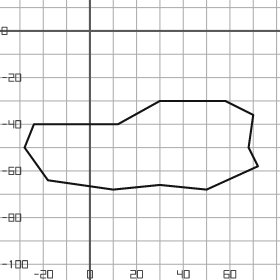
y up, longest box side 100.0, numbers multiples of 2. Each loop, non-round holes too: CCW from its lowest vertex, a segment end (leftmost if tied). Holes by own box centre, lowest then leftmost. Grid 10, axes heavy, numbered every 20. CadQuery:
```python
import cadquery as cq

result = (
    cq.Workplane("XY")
    .moveTo(10.0, -68.0)
    .lineTo(30.0, -66.0)
    .lineTo(50.0, -68.0)
    .lineTo(72.0, -58.0)
    .lineTo(68.0, -50.0)
    .lineTo(70.0, -36.0)
    .lineTo(58.0, -30.0)
    .lineTo(30.0, -30.0)
    .lineTo(12.0, -40.0)
    .lineTo(-24.0, -40.0)
    .lineTo(-28.0, -50.0)
    .lineTo(-18.0, -64.0)
    .close()
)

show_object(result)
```